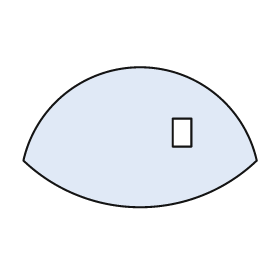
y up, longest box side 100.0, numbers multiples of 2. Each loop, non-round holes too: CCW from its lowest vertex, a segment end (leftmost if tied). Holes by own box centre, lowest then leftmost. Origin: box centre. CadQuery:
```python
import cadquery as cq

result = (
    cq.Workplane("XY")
    .moveTo(-50.0, -10.0)
    .threePointArc((0.0, -30.0), (50.0, -10.0))
    .threePointArc((0.0, 30.0), (-50.0, -10.0))
    .close()
    .moveTo(14.0, -4.0)
    .lineTo(22.0, -4.0)
    .lineTo(22.0, 8.0)
    .lineTo(14.0, 8.0)
    .close()
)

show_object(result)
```